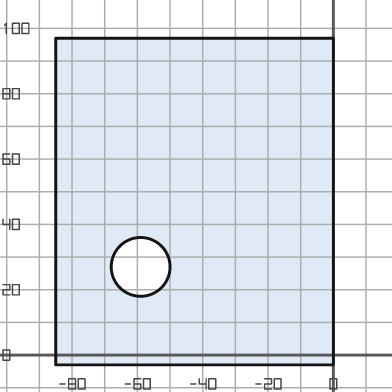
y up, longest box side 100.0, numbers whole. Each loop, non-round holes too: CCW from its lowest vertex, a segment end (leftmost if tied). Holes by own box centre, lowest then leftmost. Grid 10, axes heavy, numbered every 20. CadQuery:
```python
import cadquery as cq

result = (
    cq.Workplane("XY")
    .moveTo(-85.0, -3.0)
    .lineTo(0.0, -3.0)
    .lineTo(0.0, 97.0)
    .lineTo(-85.0, 97.0)
    .close()
    .moveTo(-59.0, 27.0)
    .circle(9.0)
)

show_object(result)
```